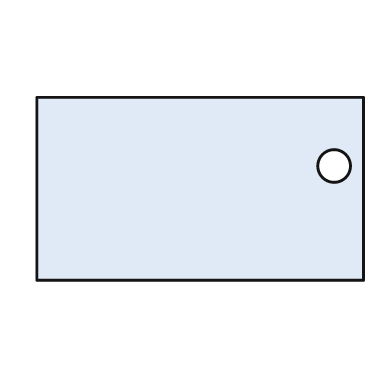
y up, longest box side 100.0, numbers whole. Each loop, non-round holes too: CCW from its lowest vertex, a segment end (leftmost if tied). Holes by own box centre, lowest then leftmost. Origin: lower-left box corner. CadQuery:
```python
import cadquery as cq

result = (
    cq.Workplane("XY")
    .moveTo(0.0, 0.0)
    .lineTo(100.0, 0.0)
    .lineTo(100.0, 56.0)
    .lineTo(0.0, 56.0)
    .close()
    .moveTo(91.0, 35.0)
    .circle(5.0)
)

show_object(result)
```